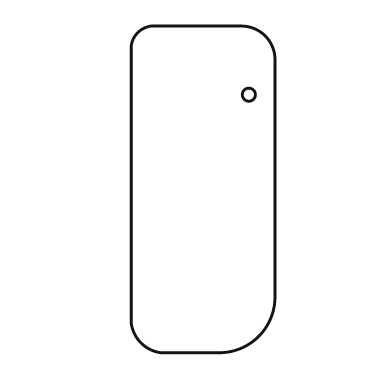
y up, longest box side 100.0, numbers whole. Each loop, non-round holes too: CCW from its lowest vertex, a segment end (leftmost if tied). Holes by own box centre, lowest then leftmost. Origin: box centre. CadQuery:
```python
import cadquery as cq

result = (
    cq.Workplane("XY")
    .moveTo(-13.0, -50.0)
    .lineTo(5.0, -50.0)
    .threePointArc((17.0, -45.0), (22.0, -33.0))
    .lineTo(22.0, 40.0)
    .threePointArc((19.0, 47.0), (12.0, 50.0))
    .lineTo(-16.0, 50.0)
    .threePointArc((-20.0, 48.0), (-22.0, 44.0))
    .lineTo(-22.0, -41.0)
    .threePointArc((-19.0, -47.0), (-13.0, -50.0))
    .close()
    .moveTo(14.0, 29.0)
    .circle(2.0)
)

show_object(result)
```